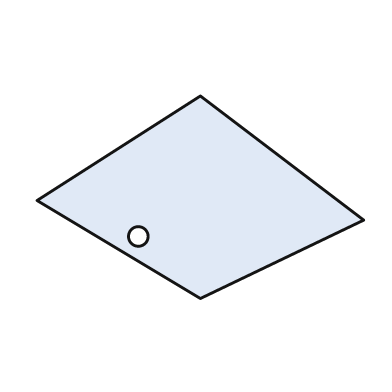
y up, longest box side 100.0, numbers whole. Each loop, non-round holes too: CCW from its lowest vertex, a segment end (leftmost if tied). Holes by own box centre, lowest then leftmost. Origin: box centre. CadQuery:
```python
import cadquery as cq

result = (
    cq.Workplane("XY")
    .moveTo(0.0, -31.0)
    .lineTo(50.0, -7.0)
    .lineTo(0.0, 31.0)
    .lineTo(-50.0, -1.0)
    .close()
    .moveTo(-19.0, -12.0)
    .circle(3.0)
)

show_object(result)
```